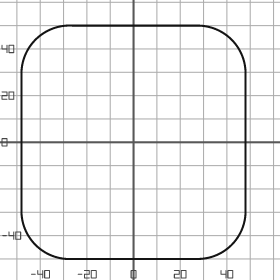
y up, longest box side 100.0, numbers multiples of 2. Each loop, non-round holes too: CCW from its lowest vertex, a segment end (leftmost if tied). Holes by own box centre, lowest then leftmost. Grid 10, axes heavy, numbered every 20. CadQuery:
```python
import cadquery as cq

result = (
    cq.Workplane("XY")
    .moveTo(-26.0, -50.0)
    .lineTo(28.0, -50.0)
    .threePointArc((42.0, -44.0), (48.0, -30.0))
    .lineTo(48.0, 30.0)
    .threePointArc((42.0, 44.0), (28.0, 50.0))
    .lineTo(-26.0, 50.0)
    .threePointArc((-42.0, 44.0), (-48.0, 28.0))
    .lineTo(-48.0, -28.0)
    .threePointArc((-42.0, -44.0), (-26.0, -50.0))
    .close()
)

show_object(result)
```